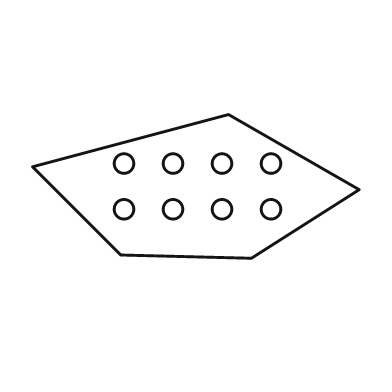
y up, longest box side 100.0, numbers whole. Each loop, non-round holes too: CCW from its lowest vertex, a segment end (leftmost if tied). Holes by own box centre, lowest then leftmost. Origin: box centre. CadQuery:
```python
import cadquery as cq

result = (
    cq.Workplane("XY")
    .moveTo(17.0, -22.0)
    .lineTo(50.0, -1.0)
    .lineTo(10.0, 22.0)
    .lineTo(-50.0, 6.0)
    .lineTo(-23.0, -21.0)
    .close()
    .moveTo(-22.0, -7.0)
    .circle(3.0)
    .moveTo(-7.0, -7.0)
    .circle(3.0)
    .moveTo(8.0, -7.0)
    .circle(3.0)
    .moveTo(23.0, -7.0)
    .circle(3.0)
    .moveTo(-22.0, 7.0)
    .circle(3.0)
    .moveTo(-7.0, 7.0)
    .circle(3.0)
    .moveTo(8.0, 7.0)
    .circle(3.0)
    .moveTo(23.0, 7.0)
    .circle(3.0)
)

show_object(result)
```